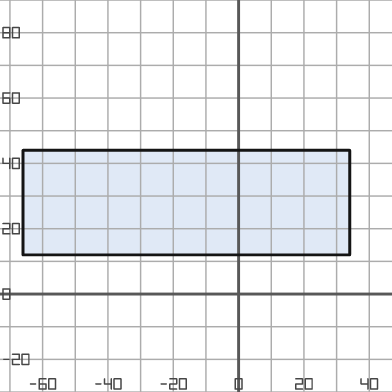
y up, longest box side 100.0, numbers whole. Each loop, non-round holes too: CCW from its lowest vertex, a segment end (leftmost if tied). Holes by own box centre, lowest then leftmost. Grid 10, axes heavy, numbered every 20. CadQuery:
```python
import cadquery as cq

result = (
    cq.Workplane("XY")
    .moveTo(-66.0, 12.0)
    .lineTo(34.0, 12.0)
    .lineTo(34.0, 44.0)
    .lineTo(-66.0, 44.0)
    .close()
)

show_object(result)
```